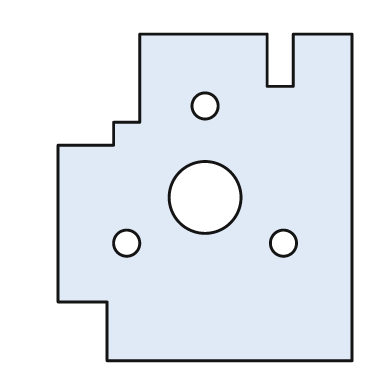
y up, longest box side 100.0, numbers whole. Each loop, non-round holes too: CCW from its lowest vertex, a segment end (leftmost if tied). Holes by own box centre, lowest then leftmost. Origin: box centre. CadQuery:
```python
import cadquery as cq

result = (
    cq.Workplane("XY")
    .moveTo(-30.0, -50.0)
    .lineTo(45.0, -50.0)
    .lineTo(45.0, 50.0)
    .lineTo(27.0, 50.0)
    .lineTo(27.0, 34.0)
    .lineTo(19.0, 34.0)
    .lineTo(19.0, 50.0)
    .lineTo(-20.0, 50.0)
    .lineTo(-20.0, 23.0)
    .lineTo(-28.0, 23.0)
    .lineTo(-28.0, 16.0)
    .lineTo(-45.0, 16.0)
    .lineTo(-45.0, -32.0)
    .lineTo(-30.0, -32.0)
    .close()
    .moveTo(-24.0, -14.0)
    .circle(4.0)
    .moveTo(24.0, -14.0)
    .circle(4.0)
    .moveTo(0.0, 0.0)
    .circle(11.0)
    .moveTo(0.0, 28.0)
    .circle(4.0)
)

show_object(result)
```